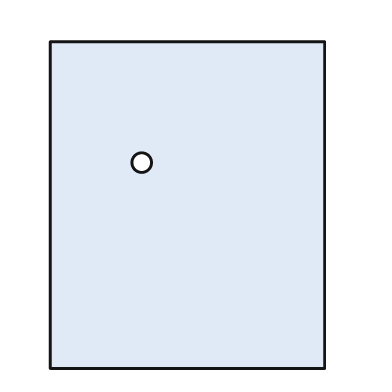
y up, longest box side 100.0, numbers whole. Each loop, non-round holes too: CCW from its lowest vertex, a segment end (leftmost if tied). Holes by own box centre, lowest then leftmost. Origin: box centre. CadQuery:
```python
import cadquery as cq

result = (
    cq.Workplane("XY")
    .moveTo(-42.0, -50.0)
    .lineTo(42.0, -50.0)
    .lineTo(42.0, 50.0)
    .lineTo(-42.0, 50.0)
    .close()
    .moveTo(-14.0, 13.0)
    .circle(3.0)
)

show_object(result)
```